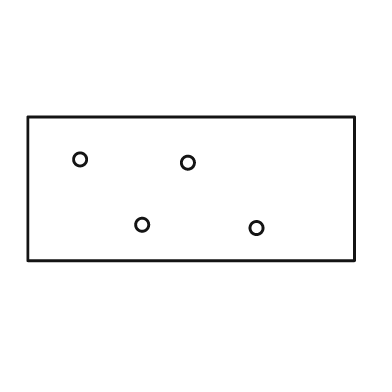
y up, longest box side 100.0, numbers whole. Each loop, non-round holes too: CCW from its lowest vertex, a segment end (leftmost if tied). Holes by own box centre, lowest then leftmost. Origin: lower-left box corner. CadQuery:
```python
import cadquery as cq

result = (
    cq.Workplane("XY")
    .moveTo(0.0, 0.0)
    .lineTo(100.0, 0.0)
    .lineTo(100.0, 44.0)
    .lineTo(0.0, 44.0)
    .close()
    .moveTo(70.0, 10.0)
    .circle(2.0)
    .moveTo(35.0, 11.0)
    .circle(2.0)
    .moveTo(49.0, 30.0)
    .circle(2.0)
    .moveTo(16.0, 31.0)
    .circle(2.0)
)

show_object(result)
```